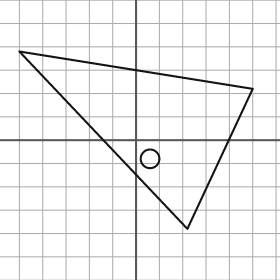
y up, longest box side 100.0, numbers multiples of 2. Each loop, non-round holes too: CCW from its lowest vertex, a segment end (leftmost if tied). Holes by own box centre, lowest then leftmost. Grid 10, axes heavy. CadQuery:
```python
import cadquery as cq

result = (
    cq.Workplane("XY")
    .moveTo(22.0, -38.0)
    .lineTo(50.0, 22.0)
    .lineTo(-50.0, 38.0)
    .close()
    .moveTo(6.0, -8.0)
    .circle(4.0)
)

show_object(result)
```